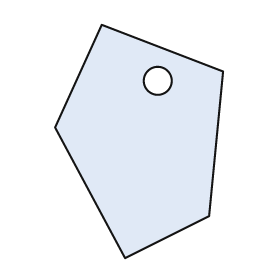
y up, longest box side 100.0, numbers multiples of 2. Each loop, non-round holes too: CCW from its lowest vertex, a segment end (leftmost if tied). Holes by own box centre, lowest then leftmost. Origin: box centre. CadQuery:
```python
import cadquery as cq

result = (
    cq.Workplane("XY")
    .moveTo(-6.0, -50.0)
    .lineTo(30.0, -32.0)
    .lineTo(36.0, 30.0)
    .lineTo(-16.0, 50.0)
    .lineTo(-36.0, 6.0)
    .close()
    .moveTo(8.0, 26.0)
    .circle(6.0)
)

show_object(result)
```